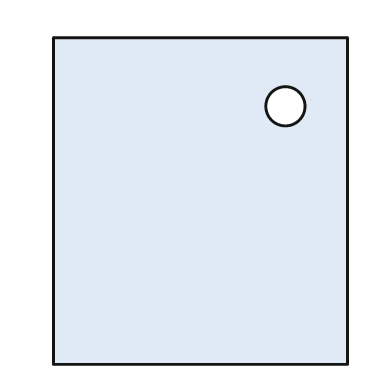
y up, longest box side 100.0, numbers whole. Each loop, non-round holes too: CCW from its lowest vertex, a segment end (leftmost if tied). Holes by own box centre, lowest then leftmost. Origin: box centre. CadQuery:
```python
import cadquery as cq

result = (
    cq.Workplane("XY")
    .moveTo(-45.0, -50.0)
    .lineTo(45.0, -50.0)
    .lineTo(45.0, 50.0)
    .lineTo(-45.0, 50.0)
    .close()
    .moveTo(26.0, 29.0)
    .circle(6.0)
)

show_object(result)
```